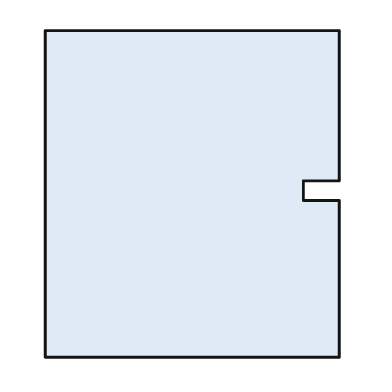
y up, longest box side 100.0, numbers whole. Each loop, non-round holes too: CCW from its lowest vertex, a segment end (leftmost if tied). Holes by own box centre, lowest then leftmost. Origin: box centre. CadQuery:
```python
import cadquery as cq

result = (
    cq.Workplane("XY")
    .moveTo(-45.0, -50.0)
    .lineTo(45.0, -50.0)
    .lineTo(45.0, -2.0)
    .lineTo(34.0, -2.0)
    .lineTo(34.0, 4.0)
    .lineTo(45.0, 4.0)
    .lineTo(45.0, 50.0)
    .lineTo(-45.0, 50.0)
    .close()
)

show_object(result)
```